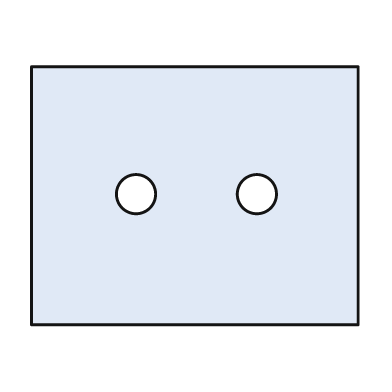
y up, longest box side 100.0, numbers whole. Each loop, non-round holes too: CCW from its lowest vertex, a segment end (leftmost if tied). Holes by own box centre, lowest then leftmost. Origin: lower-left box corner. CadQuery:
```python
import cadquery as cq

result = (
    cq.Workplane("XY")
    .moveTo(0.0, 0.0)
    .lineTo(100.0, 0.0)
    .lineTo(100.0, 79.0)
    .lineTo(0.0, 79.0)
    .close()
    .moveTo(32.0, 40.0)
    .circle(6.0)
    .moveTo(69.0, 40.0)
    .circle(6.0)
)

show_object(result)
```